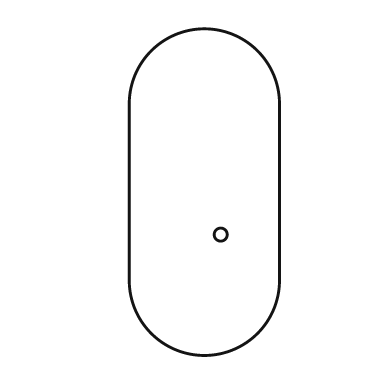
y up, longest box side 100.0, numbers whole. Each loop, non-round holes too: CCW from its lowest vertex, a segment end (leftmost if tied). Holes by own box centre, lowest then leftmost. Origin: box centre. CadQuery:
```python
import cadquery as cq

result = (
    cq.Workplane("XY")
    .moveTo(-23.0, -27.0)
    .threePointArc((0.0, -50.0), (23.0, -27.0))
    .lineTo(23.0, 27.0)
    .threePointArc((0.0, 50.0), (-23.0, 27.0))
    .close()
    .moveTo(5.0, -13.0)
    .circle(2.0)
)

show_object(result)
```